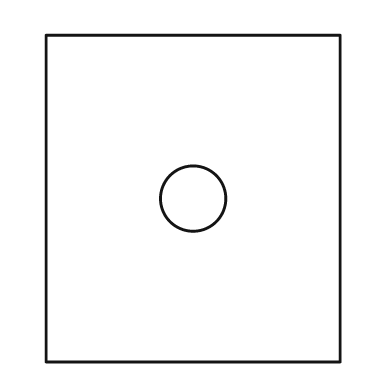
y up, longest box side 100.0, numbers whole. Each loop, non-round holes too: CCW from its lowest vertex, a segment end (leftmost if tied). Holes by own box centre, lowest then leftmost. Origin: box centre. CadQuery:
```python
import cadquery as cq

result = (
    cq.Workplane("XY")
    .moveTo(-45.0, -50.0)
    .lineTo(45.0, -50.0)
    .lineTo(45.0, 50.0)
    .lineTo(-45.0, 50.0)
    .close()
    .moveTo(0.0, 0.0)
    .circle(10.0)
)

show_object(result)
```